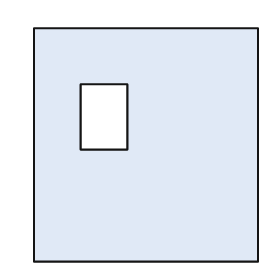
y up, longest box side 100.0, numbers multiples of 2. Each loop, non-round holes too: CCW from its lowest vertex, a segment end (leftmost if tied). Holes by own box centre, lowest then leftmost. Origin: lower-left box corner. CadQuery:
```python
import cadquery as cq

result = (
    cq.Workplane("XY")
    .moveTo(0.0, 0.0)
    .lineTo(96.0, 0.0)
    .lineTo(96.0, 100.0)
    .lineTo(0.0, 100.0)
    .close()
    .moveTo(20.0, 48.0)
    .lineTo(40.0, 48.0)
    .lineTo(40.0, 76.0)
    .lineTo(20.0, 76.0)
    .close()
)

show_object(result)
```